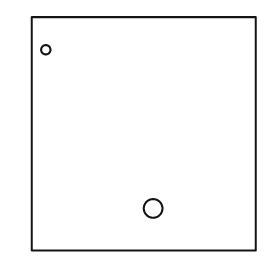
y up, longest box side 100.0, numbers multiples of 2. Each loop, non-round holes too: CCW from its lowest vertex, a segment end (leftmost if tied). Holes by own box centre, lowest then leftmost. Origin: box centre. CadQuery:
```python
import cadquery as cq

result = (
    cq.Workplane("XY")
    .moveTo(-48.0, -50.0)
    .lineTo(48.0, -50.0)
    .lineTo(48.0, 50.0)
    .lineTo(-48.0, 50.0)
    .close()
    .moveTo(4.0, -32.0)
    .circle(4.0)
    .moveTo(-42.0, 36.0)
    .circle(2.0)
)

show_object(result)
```